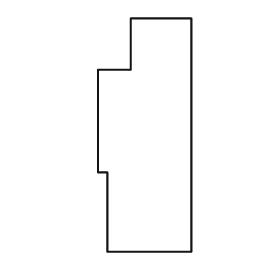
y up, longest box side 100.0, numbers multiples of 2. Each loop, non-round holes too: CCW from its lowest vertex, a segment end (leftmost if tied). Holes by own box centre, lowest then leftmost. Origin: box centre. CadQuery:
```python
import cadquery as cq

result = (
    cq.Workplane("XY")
    .moveTo(-16.0, -50.0)
    .lineTo(20.0, -50.0)
    .lineTo(20.0, 50.0)
    .lineTo(-6.0, 50.0)
    .lineTo(-6.0, 28.0)
    .lineTo(-20.0, 28.0)
    .lineTo(-20.0, -16.0)
    .lineTo(-16.0, -16.0)
    .close()
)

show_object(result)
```